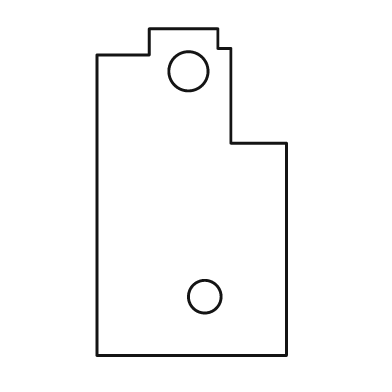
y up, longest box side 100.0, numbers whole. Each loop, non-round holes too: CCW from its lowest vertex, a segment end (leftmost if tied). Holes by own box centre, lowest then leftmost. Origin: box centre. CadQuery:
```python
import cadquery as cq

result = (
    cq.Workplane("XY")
    .moveTo(-29.0, -50.0)
    .lineTo(29.0, -50.0)
    .lineTo(29.0, 15.0)
    .lineTo(12.0, 15.0)
    .lineTo(12.0, 44.0)
    .lineTo(8.0, 44.0)
    .lineTo(8.0, 50.0)
    .lineTo(-13.0, 50.0)
    .lineTo(-13.0, 42.0)
    .lineTo(-29.0, 42.0)
    .close()
    .moveTo(4.0, -32.0)
    .circle(5.0)
    .moveTo(-1.0, 37.0)
    .circle(6.0)
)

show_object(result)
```